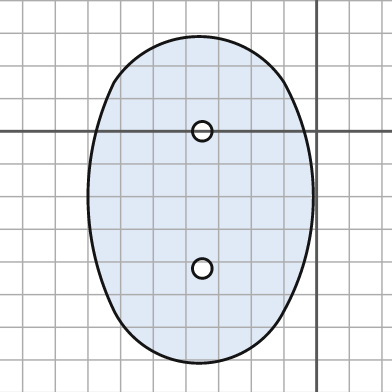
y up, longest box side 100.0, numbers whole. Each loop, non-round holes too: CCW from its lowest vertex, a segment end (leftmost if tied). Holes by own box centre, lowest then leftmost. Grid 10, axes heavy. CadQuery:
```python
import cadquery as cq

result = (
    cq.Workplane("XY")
    .moveTo(-62.0, -55.0)
    .threePointArc((-36.0, -71.0), (-10.0, -55.0))
    .threePointArc((-1.0, -20.0), (-10.0, 15.0))
    .threePointArc((-36.0, 29.0), (-62.0, 15.0))
    .threePointArc((-70.0, -20.0), (-62.0, -55.0))
    .close()
    .moveTo(-35.0, -42.0)
    .circle(3.0)
    .moveTo(-35.0, 0.0)
    .circle(3.0)
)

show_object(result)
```